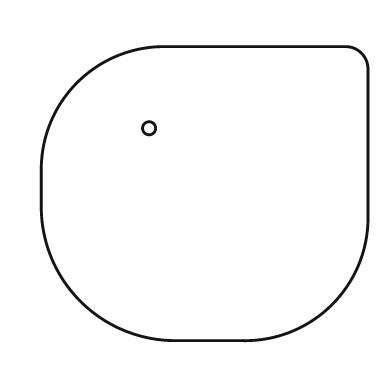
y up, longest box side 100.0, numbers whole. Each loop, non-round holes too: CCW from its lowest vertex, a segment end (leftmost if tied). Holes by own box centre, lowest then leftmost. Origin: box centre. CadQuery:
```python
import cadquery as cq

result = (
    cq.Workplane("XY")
    .moveTo(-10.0, -45.0)
    .lineTo(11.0, -45.0)
    .threePointArc((39.0, -34.0), (50.0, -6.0))
    .lineTo(50.0, 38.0)
    .threePointArc((48.0, 43.0), (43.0, 45.0))
    .lineTo(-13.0, 45.0)
    .threePointArc((-39.0, 34.0), (-50.0, 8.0))
    .lineTo(-50.0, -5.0)
    .threePointArc((-38.0, -33.0), (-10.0, -45.0))
    .close()
    .moveTo(-17.0, 20.0)
    .circle(2.0)
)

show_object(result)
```